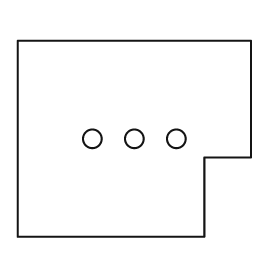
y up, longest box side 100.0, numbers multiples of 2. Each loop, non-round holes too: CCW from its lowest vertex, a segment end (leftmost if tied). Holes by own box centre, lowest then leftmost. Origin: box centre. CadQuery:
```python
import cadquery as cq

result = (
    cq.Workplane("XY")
    .moveTo(-50.0, -42.0)
    .lineTo(30.0, -42.0)
    .lineTo(30.0, -8.0)
    .lineTo(50.0, -8.0)
    .lineTo(50.0, 42.0)
    .lineTo(-50.0, 42.0)
    .close()
    .moveTo(-18.0, 0.0)
    .circle(4.0)
    .moveTo(0.0, 0.0)
    .circle(4.0)
    .moveTo(18.0, 0.0)
    .circle(4.0)
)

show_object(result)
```